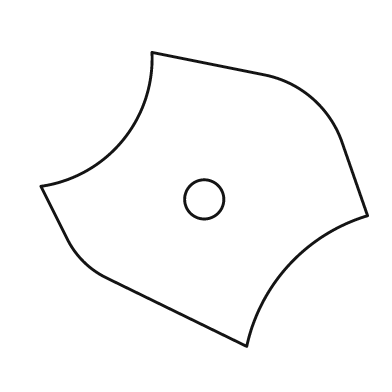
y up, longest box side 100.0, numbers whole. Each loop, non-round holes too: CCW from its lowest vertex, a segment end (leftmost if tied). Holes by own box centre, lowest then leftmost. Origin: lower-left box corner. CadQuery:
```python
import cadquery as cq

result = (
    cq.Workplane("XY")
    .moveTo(63.0, 0.0)
    .threePointArc((76.0, 25.0), (100.0, 40.0))
    .lineTo(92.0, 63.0)
    .threePointArc((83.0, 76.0), (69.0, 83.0))
    .lineTo(34.0, 90.0)
    .threePointArc((25.0, 63.0), (0.0, 49.0))
    .lineTo(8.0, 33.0)
    .threePointArc((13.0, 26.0), (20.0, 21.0))
    .close()
    .moveTo(50.0, 45.0)
    .circle(6.0)
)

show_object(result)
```